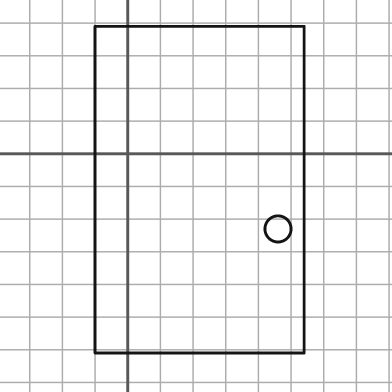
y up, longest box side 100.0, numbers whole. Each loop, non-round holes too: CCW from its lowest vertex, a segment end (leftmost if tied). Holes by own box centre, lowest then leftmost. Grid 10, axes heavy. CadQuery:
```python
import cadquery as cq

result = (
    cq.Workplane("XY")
    .moveTo(-10.0, -61.0)
    .lineTo(54.0, -61.0)
    .lineTo(54.0, 39.0)
    .lineTo(-10.0, 39.0)
    .close()
    .moveTo(46.0, -23.0)
    .circle(4.0)
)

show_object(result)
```